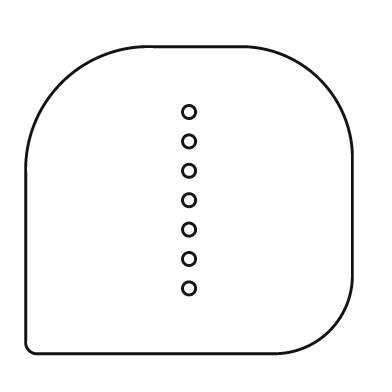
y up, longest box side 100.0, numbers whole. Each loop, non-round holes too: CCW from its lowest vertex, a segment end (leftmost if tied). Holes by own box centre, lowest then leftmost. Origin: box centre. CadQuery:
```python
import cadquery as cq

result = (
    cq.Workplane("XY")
    .moveTo(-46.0, -47.0)
    .lineTo(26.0, -47.0)
    .threePointArc((43.0, -40.0), (50.0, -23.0))
    .lineTo(50.0, 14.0)
    .threePointArc((40.0, 37.0), (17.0, 47.0))
    .lineTo(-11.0, 47.0)
    .threePointArc((-39.0, 36.0), (-50.0, 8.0))
    .lineTo(-50.0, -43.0)
    .threePointArc((-49.0, -46.0), (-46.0, -47.0))
    .close()
    .moveTo(0.0, -27.0)
    .circle(2.0)
    .moveTo(0.0, -18.0)
    .circle(2.0)
    .moveTo(0.0, -9.0)
    .circle(2.0)
    .moveTo(0.0, 0.0)
    .circle(2.0)
    .moveTo(0.0, 9.0)
    .circle(2.0)
    .moveTo(0.0, 18.0)
    .circle(2.0)
    .moveTo(0.0, 27.0)
    .circle(2.0)
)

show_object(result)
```